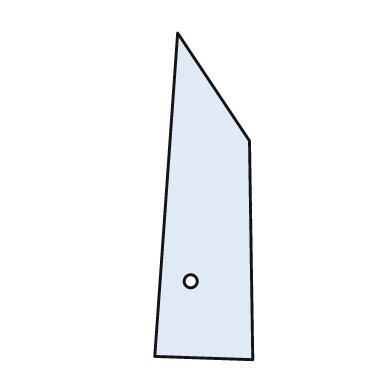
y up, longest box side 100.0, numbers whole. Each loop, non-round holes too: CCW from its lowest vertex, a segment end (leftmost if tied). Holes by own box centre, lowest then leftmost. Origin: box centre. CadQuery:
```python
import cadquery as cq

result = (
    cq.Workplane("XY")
    .moveTo(15.0, -50.0)
    .lineTo(14.0, 17.0)
    .lineTo(-8.0, 50.0)
    .lineTo(-15.0, -49.0)
    .close()
    .moveTo(-4.0, -26.0)
    .circle(2.0)
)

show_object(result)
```